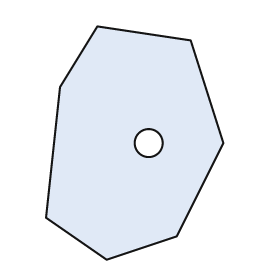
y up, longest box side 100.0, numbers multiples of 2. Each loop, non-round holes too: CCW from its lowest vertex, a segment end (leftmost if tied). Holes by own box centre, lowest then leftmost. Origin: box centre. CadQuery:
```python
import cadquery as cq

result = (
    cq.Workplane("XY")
    .moveTo(-12.0, -50.0)
    .lineTo(18.0, -40.0)
    .lineTo(38.0, 0.0)
    .lineTo(24.0, 44.0)
    .lineTo(-16.0, 50.0)
    .lineTo(-32.0, 24.0)
    .lineTo(-38.0, -32.0)
    .close()
    .moveTo(6.0, 0.0)
    .circle(6.0)
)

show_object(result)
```